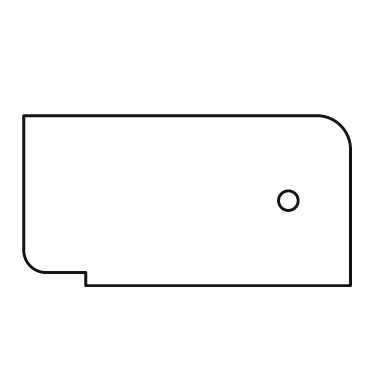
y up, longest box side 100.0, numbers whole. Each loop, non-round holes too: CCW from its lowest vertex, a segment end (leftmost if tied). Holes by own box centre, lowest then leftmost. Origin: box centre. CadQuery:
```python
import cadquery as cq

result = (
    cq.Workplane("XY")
    .moveTo(-31.0, -26.0)
    .lineTo(50.0, -26.0)
    .lineTo(50.0, 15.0)
    .threePointArc((47.0, 23.0), (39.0, 26.0))
    .lineTo(-50.0, 26.0)
    .lineTo(-50.0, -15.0)
    .threePointArc((-48.0, -20.0), (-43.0, -22.0))
    .lineTo(-31.0, -22.0)
    .close()
    .moveTo(31.0, 0.0)
    .circle(3.0)
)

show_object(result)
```